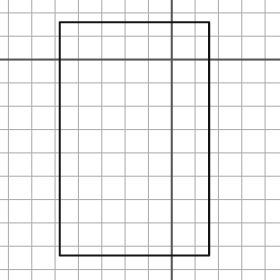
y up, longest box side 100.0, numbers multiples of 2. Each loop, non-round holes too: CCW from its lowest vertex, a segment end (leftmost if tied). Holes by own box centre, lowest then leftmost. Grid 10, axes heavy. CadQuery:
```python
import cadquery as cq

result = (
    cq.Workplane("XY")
    .moveTo(-48.0, -84.0)
    .lineTo(16.0, -84.0)
    .lineTo(16.0, 16.0)
    .lineTo(-48.0, 16.0)
    .close()
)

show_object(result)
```